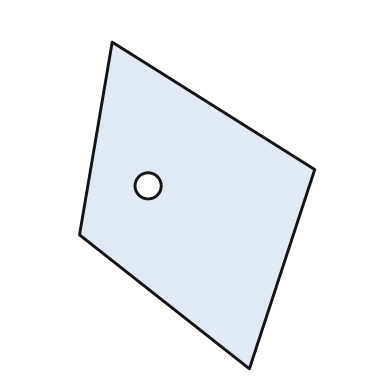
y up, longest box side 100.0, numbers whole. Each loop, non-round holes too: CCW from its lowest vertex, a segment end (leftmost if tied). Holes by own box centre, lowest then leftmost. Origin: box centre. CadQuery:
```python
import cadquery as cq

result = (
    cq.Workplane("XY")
    .moveTo(16.0, -50.0)
    .lineTo(36.0, 11.0)
    .lineTo(-26.0, 50.0)
    .lineTo(-36.0, -9.0)
    .close()
    .moveTo(-15.0, 6.0)
    .circle(4.0)
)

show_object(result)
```